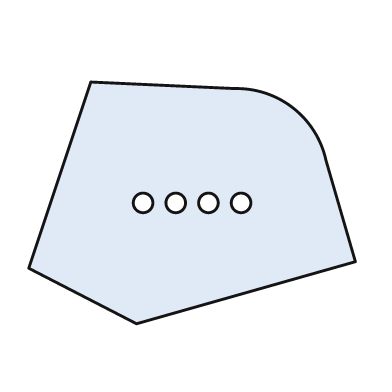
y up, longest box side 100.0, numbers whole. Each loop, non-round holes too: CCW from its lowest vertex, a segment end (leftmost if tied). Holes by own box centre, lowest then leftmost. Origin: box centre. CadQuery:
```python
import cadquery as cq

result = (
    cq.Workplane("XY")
    .moveTo(-17.0, -37.0)
    .lineTo(50.0, -18.0)
    .lineTo(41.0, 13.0)
    .threePointArc((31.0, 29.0), (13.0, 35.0))
    .lineTo(-31.0, 37.0)
    .lineTo(-50.0, -20.0)
    .close()
    .moveTo(-15.0, 0.0)
    .circle(3.0)
    .moveTo(-5.0, 0.0)
    .circle(3.0)
    .moveTo(5.0, 0.0)
    .circle(3.0)
    .moveTo(15.0, 0.0)
    .circle(3.0)
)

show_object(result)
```